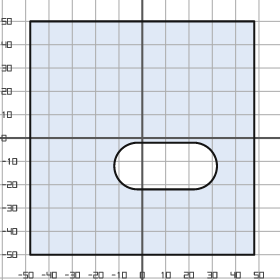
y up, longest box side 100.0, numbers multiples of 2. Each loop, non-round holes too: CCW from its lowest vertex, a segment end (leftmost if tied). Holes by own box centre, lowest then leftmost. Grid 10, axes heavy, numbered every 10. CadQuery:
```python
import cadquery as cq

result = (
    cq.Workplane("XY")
    .moveTo(-48.0, -50.0)
    .lineTo(48.0, -50.0)
    .lineTo(48.0, 50.0)
    .lineTo(-48.0, 50.0)
    .close()
    .moveTo(-2.0, -22.0)
    .lineTo(22.0, -22.0)
    .threePointArc((32.0, -12.0), (22.0, -2.0))
    .lineTo(-2.0, -2.0)
    .threePointArc((-12.0, -12.0), (-2.0, -22.0))
    .close()
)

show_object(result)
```